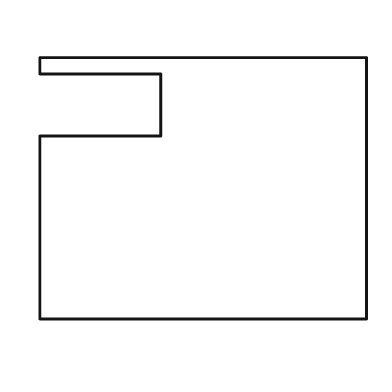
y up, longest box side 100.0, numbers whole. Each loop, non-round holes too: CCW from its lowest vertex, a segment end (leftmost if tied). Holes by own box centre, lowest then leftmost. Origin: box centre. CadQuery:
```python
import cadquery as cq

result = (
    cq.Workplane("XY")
    .moveTo(-50.0, -40.0)
    .lineTo(50.0, -40.0)
    .lineTo(50.0, 40.0)
    .lineTo(-50.0, 40.0)
    .lineTo(-50.0, 35.0)
    .lineTo(-13.0, 35.0)
    .lineTo(-13.0, 16.0)
    .lineTo(-50.0, 16.0)
    .close()
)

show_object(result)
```